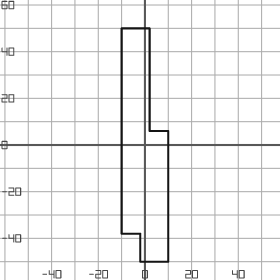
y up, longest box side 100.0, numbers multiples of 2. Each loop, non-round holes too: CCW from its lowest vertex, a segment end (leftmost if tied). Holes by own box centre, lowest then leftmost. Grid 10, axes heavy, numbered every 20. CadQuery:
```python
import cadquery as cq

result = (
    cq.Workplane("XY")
    .moveTo(-2.0, -50.0)
    .lineTo(10.0, -50.0)
    .lineTo(10.0, 6.0)
    .lineTo(2.0, 6.0)
    .lineTo(2.0, 50.0)
    .lineTo(-10.0, 50.0)
    .lineTo(-10.0, -38.0)
    .lineTo(-2.0, -38.0)
    .close()
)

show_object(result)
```